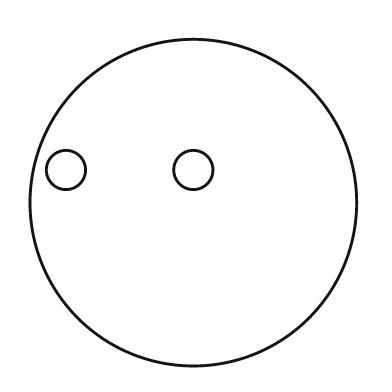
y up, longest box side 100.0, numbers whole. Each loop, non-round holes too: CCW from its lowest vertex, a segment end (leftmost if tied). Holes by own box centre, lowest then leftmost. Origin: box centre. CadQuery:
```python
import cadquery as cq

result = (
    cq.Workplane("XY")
    .moveTo(0.0, 0.0)
    .circle(50.0)
    .moveTo(-39.0, 10.0)
    .circle(6.0)
    .moveTo(0.0, 10.0)
    .circle(6.0)
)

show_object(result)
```